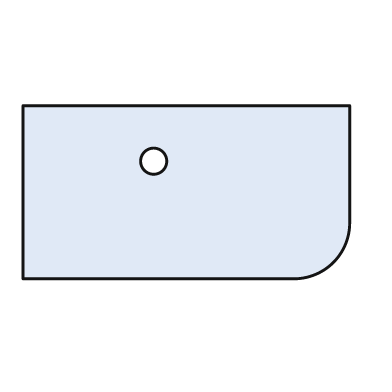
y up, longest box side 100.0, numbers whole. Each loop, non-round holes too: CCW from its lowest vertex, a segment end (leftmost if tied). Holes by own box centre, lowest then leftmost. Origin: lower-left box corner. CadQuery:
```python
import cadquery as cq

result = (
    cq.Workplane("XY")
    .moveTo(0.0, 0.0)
    .lineTo(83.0, 0.0)
    .threePointArc((95.0, 5.0), (100.0, 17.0))
    .lineTo(100.0, 53.0)
    .lineTo(0.0, 53.0)
    .close()
    .moveTo(40.0, 36.0)
    .circle(4.0)
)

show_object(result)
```